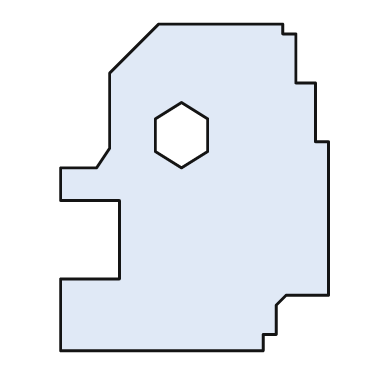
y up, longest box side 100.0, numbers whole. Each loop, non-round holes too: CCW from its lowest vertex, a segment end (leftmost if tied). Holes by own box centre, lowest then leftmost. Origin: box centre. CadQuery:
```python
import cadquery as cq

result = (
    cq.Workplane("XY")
    .moveTo(-41.0, -50.0)
    .lineTo(21.0, -50.0)
    .lineTo(21.0, -45.0)
    .lineTo(25.0, -45.0)
    .lineTo(25.0, -36.0)
    .lineTo(28.0, -33.0)
    .lineTo(41.0, -33.0)
    .lineTo(41.0, 14.0)
    .lineTo(37.0, 14.0)
    .lineTo(37.0, 32.0)
    .lineTo(31.0, 32.0)
    .lineTo(31.0, 47.0)
    .lineTo(27.0, 47.0)
    .lineTo(27.0, 50.0)
    .lineTo(-11.0, 50.0)
    .lineTo(-26.0, 35.0)
    .lineTo(-26.0, 12.0)
    .lineTo(-30.0, 6.0)
    .lineTo(-41.0, 6.0)
    .lineTo(-41.0, -4.0)
    .lineTo(-23.0, -4.0)
    .lineTo(-23.0, -28.0)
    .lineTo(-41.0, -28.0)
    .close()
    .moveTo(-4.0, 6.0)
    .lineTo(4.0, 11.0)
    .lineTo(4.0, 21.0)
    .lineTo(-4.0, 26.0)
    .lineTo(-12.0, 21.0)
    .lineTo(-12.0, 11.0)
    .close()
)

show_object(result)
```